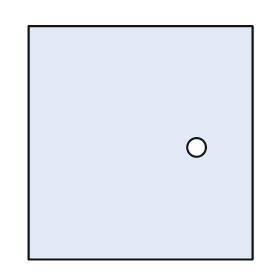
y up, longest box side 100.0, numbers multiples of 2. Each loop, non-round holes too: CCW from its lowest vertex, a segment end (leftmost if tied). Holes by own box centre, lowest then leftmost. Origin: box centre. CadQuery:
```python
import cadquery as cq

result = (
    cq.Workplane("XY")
    .moveTo(-48.0, -50.0)
    .lineTo(48.0, -50.0)
    .lineTo(48.0, 50.0)
    .lineTo(-48.0, 50.0)
    .close()
    .moveTo(24.0, -2.0)
    .circle(4.0)
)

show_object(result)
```